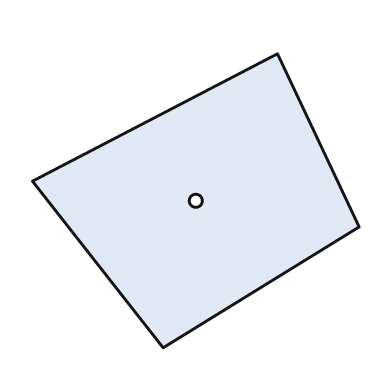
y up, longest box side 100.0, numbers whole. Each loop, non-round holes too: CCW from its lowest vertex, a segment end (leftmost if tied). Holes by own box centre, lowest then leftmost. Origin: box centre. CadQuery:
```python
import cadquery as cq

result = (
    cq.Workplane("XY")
    .moveTo(-10.0, -45.0)
    .lineTo(50.0, -8.0)
    .lineTo(25.0, 45.0)
    .lineTo(-50.0, 6.0)
    .close()
    .moveTo(0.0, 0.0)
    .circle(2.0)
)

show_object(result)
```